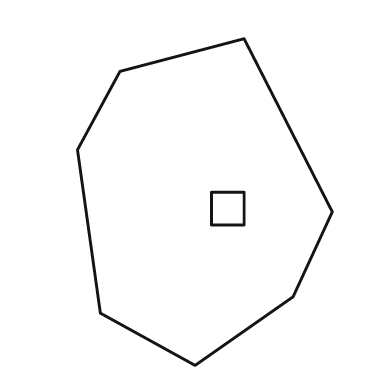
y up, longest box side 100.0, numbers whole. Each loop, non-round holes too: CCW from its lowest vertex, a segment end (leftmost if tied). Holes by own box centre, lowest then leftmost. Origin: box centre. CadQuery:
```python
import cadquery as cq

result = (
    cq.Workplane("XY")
    .moveTo(-3.0, -50.0)
    .lineTo(27.0, -29.0)
    .lineTo(39.0, -3.0)
    .lineTo(12.0, 50.0)
    .lineTo(-26.0, 40.0)
    .lineTo(-39.0, 16.0)
    .lineTo(-32.0, -34.0)
    .close()
    .moveTo(2.0, -7.0)
    .lineTo(12.0, -7.0)
    .lineTo(12.0, 3.0)
    .lineTo(2.0, 3.0)
    .close()
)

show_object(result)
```